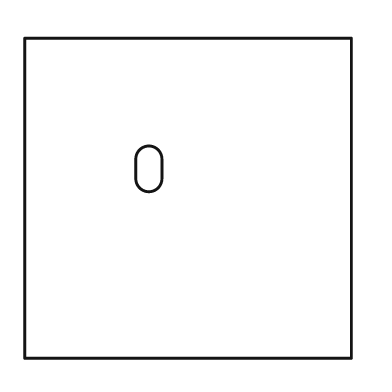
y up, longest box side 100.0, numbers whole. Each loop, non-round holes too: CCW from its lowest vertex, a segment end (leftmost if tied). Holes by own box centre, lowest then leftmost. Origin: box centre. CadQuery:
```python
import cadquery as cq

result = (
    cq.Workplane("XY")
    .moveTo(-50.0, -49.0)
    .lineTo(50.0, -49.0)
    .lineTo(50.0, 49.0)
    .lineTo(-50.0, 49.0)
    .close()
    .moveTo(-16.0, 6.0)
    .threePointArc((-12.0, 2.0), (-8.0, 6.0))
    .lineTo(-8.0, 12.0)
    .threePointArc((-12.0, 16.0), (-16.0, 12.0))
    .close()
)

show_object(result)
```